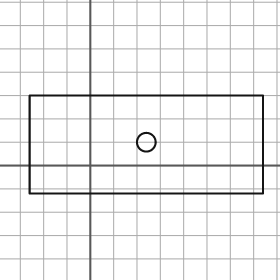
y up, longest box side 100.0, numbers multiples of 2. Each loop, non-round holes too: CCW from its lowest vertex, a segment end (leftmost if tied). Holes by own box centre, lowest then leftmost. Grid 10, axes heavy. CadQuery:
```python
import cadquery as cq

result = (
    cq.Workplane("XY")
    .moveTo(-26.0, -12.0)
    .lineTo(74.0, -12.0)
    .lineTo(74.0, 30.0)
    .lineTo(-26.0, 30.0)
    .close()
    .moveTo(24.0, 10.0)
    .circle(4.0)
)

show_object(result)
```